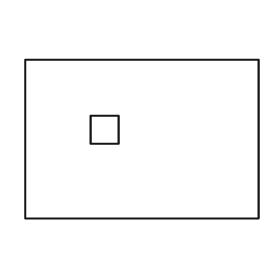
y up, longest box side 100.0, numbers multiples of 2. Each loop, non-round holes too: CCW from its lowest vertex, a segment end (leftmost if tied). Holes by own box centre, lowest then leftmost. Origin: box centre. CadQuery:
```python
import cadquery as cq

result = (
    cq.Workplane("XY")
    .moveTo(-50.0, -34.0)
    .lineTo(50.0, -34.0)
    .lineTo(50.0, 34.0)
    .lineTo(-50.0, 34.0)
    .close()
    .moveTo(-22.0, -2.0)
    .lineTo(-10.0, -2.0)
    .lineTo(-10.0, 10.0)
    .lineTo(-22.0, 10.0)
    .close()
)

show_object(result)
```